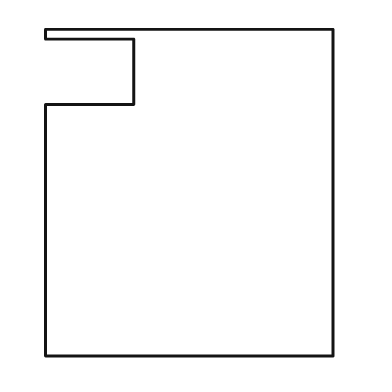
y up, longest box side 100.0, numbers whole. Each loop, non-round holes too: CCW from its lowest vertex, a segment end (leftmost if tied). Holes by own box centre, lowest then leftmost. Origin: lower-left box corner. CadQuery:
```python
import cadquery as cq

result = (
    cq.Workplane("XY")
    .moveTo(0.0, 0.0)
    .lineTo(88.0, 0.0)
    .lineTo(88.0, 100.0)
    .lineTo(0.0, 100.0)
    .lineTo(0.0, 97.0)
    .lineTo(27.0, 97.0)
    .lineTo(27.0, 77.0)
    .lineTo(0.0, 77.0)
    .close()
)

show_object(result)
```